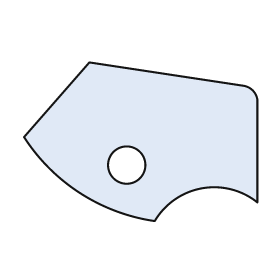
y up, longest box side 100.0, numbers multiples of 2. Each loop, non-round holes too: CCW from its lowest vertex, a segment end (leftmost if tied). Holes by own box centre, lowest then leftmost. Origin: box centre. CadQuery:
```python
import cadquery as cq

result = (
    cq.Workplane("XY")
    .moveTo(6.0, -34.0)
    .threePointArc((26.0, -20.0), (50.0, -26.0))
    .lineTo(50.0, 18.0)
    .threePointArc((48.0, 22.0), (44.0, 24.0))
    .lineTo(-22.0, 34.0)
    .lineTo(-50.0, 2.0)
    .threePointArc((-26.0, -22.0), (6.0, -34.0))
    .close()
    .moveTo(-6.0, -10.0)
    .circle(8.0)
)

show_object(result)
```